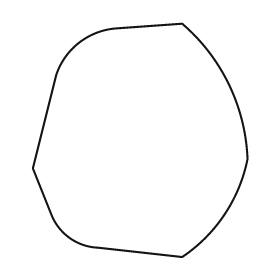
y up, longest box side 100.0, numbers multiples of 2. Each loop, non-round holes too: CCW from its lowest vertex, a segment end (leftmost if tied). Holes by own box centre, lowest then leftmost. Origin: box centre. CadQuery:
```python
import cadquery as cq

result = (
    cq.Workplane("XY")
    .moveTo(18.0, -50.0)
    .threePointArc((36.0, -32.0), (46.0, -8.0))
    .threePointArc((38.0, 24.0), (18.0, 50.0))
    .lineTo(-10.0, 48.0)
    .threePointArc((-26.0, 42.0), (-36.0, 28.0))
    .lineTo(-46.0, -12.0)
    .lineTo(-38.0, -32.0)
    .threePointArc((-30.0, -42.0), (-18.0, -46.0))
    .close()
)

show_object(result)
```